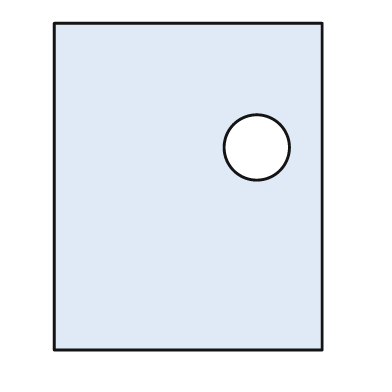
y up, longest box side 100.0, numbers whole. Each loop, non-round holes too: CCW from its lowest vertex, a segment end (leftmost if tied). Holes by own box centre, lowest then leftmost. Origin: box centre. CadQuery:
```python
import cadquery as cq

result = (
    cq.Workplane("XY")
    .moveTo(-41.0, -50.0)
    .lineTo(41.0, -50.0)
    .lineTo(41.0, 50.0)
    .lineTo(-41.0, 50.0)
    .close()
    .moveTo(21.0, 12.0)
    .circle(10.0)
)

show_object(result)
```